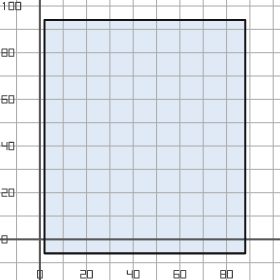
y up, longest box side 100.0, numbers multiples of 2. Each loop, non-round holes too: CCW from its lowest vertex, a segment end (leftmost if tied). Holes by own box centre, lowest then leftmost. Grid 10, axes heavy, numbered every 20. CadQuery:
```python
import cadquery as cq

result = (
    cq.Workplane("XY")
    .moveTo(2.0, -6.0)
    .lineTo(88.0, -6.0)
    .lineTo(88.0, 94.0)
    .lineTo(2.0, 94.0)
    .close()
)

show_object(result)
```